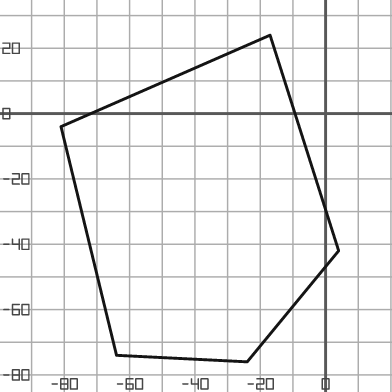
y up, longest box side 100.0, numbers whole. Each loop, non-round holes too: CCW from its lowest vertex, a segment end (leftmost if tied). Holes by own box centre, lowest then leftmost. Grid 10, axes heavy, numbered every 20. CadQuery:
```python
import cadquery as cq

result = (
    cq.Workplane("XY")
    .moveTo(-24.0, -76.0)
    .lineTo(4.0, -42.0)
    .lineTo(-17.0, 24.0)
    .lineTo(-81.0, -4.0)
    .lineTo(-64.0, -74.0)
    .close()
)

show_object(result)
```